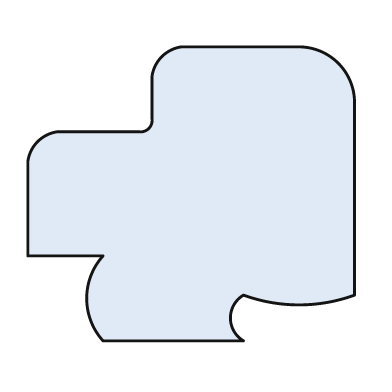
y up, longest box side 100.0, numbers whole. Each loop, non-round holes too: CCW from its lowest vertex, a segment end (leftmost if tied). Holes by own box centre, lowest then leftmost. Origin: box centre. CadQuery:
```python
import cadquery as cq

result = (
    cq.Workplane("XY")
    .moveTo(-27.0, -45.0)
    .lineTo(16.0, -45.0)
    .threePointArc((12.0, -38.0), (16.0, -31.0))
    .threePointArc((33.0, -34.0), (50.0, -31.0))
    .lineTo(50.0, 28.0)
    .threePointArc((45.0, 40.0), (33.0, 45.0))
    .lineTo(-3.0, 45.0)
    .threePointArc((-9.0, 42.0), (-12.0, 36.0))
    .lineTo(-12.0, 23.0)
    .threePointArc((-13.0, 20.0), (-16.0, 19.0))
    .lineTo(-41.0, 19.0)
    .threePointArc((-47.0, 16.0), (-50.0, 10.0))
    .lineTo(-50.0, -19.0)
    .lineTo(-27.0, -19.0)
    .threePointArc((-32.0, -32.0), (-27.0, -45.0))
    .close()
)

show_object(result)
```